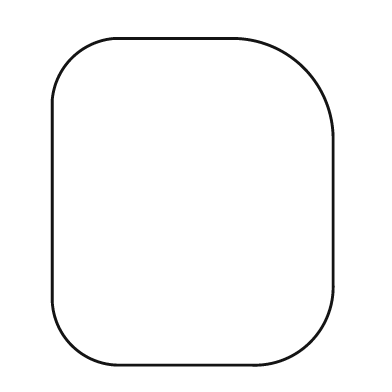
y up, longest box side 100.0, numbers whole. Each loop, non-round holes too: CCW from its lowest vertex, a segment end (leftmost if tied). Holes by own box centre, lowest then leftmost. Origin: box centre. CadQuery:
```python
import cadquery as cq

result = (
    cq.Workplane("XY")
    .moveTo(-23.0, -50.0)
    .lineTo(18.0, -50.0)
    .threePointArc((36.0, -43.0), (43.0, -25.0))
    .lineTo(43.0, 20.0)
    .threePointArc((34.0, 41.0), (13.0, 50.0))
    .lineTo(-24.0, 50.0)
    .threePointArc((-37.0, 44.0), (-43.0, 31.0))
    .lineTo(-43.0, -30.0)
    .threePointArc((-37.0, -44.0), (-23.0, -50.0))
    .close()
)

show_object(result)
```